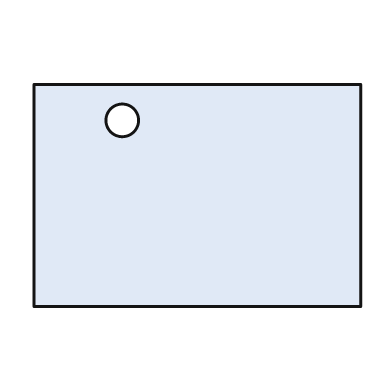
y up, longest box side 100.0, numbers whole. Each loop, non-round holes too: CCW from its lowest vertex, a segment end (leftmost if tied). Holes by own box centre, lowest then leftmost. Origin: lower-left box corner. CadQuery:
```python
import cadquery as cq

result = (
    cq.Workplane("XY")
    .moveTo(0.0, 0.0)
    .lineTo(100.0, 0.0)
    .lineTo(100.0, 68.0)
    .lineTo(0.0, 68.0)
    .close()
    .moveTo(27.0, 57.0)
    .circle(5.0)
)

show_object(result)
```